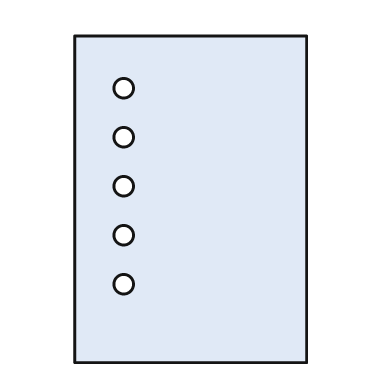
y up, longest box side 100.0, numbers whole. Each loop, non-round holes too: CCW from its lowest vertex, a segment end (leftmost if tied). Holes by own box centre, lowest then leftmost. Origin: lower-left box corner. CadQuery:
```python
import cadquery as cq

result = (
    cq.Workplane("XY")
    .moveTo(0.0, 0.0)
    .lineTo(71.0, 0.0)
    .lineTo(71.0, 100.0)
    .lineTo(0.0, 100.0)
    .close()
    .moveTo(15.0, 24.0)
    .circle(3.0)
    .moveTo(15.0, 39.0)
    .circle(3.0)
    .moveTo(15.0, 54.0)
    .circle(3.0)
    .moveTo(15.0, 69.0)
    .circle(3.0)
    .moveTo(15.0, 84.0)
    .circle(3.0)
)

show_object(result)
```